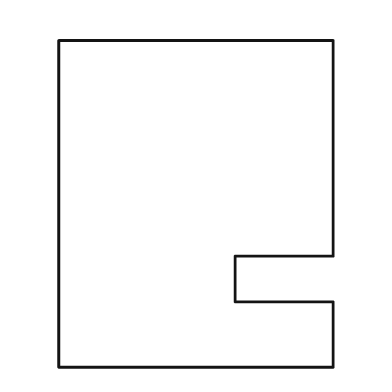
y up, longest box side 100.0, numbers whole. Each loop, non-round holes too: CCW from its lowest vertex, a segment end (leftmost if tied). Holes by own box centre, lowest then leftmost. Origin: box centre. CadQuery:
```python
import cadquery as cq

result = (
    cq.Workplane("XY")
    .moveTo(-42.0, -50.0)
    .lineTo(42.0, -50.0)
    .lineTo(42.0, -30.0)
    .lineTo(12.0, -30.0)
    .lineTo(12.0, -16.0)
    .lineTo(42.0, -16.0)
    .lineTo(42.0, 50.0)
    .lineTo(-42.0, 50.0)
    .close()
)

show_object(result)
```